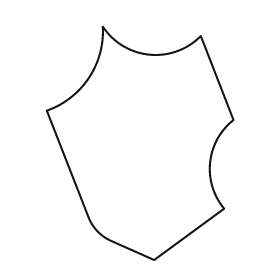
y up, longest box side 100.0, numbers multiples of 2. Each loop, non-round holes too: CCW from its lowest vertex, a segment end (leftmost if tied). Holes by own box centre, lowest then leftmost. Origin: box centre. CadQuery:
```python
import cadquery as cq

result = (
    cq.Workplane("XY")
    .moveTo(6.0, -50.0)
    .lineTo(36.0, -28.0)
    .threePointArc((30.0, -8.0), (40.0, 10.0))
    .lineTo(26.0, 46.0)
    .threePointArc((4.0, 38.0), (-16.0, 50.0))
    .threePointArc((-22.0, 28.0), (-40.0, 14.0))
    .lineTo(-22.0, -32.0)
    .threePointArc((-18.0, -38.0), (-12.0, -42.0))
    .close()
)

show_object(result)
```